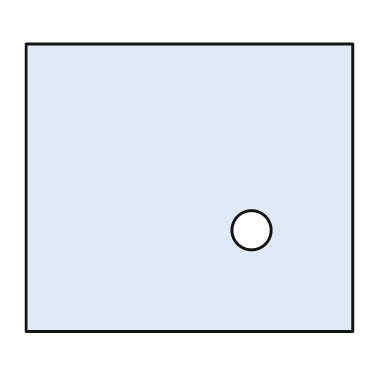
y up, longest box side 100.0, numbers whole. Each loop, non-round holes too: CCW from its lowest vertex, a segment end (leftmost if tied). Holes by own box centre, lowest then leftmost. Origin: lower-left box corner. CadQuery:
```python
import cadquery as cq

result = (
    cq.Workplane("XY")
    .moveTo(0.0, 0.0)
    .lineTo(100.0, 0.0)
    .lineTo(100.0, 88.0)
    .lineTo(0.0, 88.0)
    .close()
    .moveTo(69.0, 31.0)
    .circle(6.0)
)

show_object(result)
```